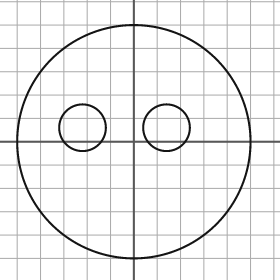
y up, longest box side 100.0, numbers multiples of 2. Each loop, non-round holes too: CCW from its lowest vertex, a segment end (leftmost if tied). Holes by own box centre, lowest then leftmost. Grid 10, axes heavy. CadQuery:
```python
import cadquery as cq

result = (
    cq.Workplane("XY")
    .moveTo(0.0, 0.0)
    .circle(50.0)
    .moveTo(-22.0, 6.0)
    .circle(10.0)
    .moveTo(14.0, 6.0)
    .circle(10.0)
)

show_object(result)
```